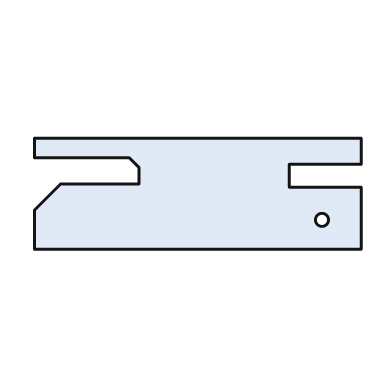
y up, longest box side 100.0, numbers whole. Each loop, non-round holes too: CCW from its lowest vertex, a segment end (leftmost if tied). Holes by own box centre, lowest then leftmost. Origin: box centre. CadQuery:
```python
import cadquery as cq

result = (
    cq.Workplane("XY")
    .moveTo(-50.0, -17.0)
    .lineTo(50.0, -17.0)
    .lineTo(50.0, 2.0)
    .lineTo(28.0, 2.0)
    .lineTo(28.0, 9.0)
    .lineTo(50.0, 9.0)
    .lineTo(50.0, 17.0)
    .lineTo(-50.0, 17.0)
    .lineTo(-50.0, 11.0)
    .lineTo(-21.0, 11.0)
    .lineTo(-18.0, 8.0)
    .lineTo(-18.0, 3.0)
    .lineTo(-42.0, 3.0)
    .lineTo(-50.0, -5.0)
    .close()
    .moveTo(38.0, -8.0)
    .circle(2.0)
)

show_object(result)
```